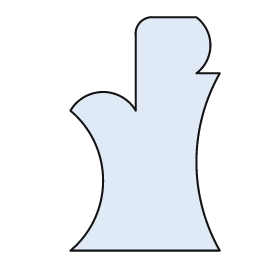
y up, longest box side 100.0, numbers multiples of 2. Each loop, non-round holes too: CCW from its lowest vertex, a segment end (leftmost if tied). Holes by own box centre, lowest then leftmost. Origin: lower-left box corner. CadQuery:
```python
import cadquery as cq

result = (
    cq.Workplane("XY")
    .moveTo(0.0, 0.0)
    .lineTo(64.0, 0.0)
    .threePointArc((54.0, 38.0), (64.0, 76.0))
    .lineTo(54.0, 76.0)
    .threePointArc((60.0, 88.0), (54.0, 100.0))
    .lineTo(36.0, 100.0)
    .threePointArc((30.0, 98.0), (28.0, 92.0))
    .lineTo(28.0, 60.0)
    .threePointArc((14.0, 68.0), (0.0, 60.0))
    .threePointArc((14.0, 30.0), (0.0, 0.0))
    .close()
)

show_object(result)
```